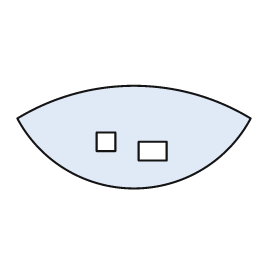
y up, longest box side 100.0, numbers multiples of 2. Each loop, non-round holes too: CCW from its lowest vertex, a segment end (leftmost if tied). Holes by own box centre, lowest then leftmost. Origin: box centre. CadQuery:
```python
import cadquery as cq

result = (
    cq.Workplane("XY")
    .moveTo(-50.0, 8.0)
    .threePointArc((0.0, -22.0), (50.0, 8.0))
    .threePointArc((0.0, 22.0), (-50.0, 8.0))
    .close()
    .moveTo(2.0, -10.0)
    .lineTo(14.0, -10.0)
    .lineTo(14.0, -2.0)
    .lineTo(2.0, -2.0)
    .close()
    .moveTo(-16.0, -6.0)
    .lineTo(-8.0, -6.0)
    .lineTo(-8.0, 2.0)
    .lineTo(-16.0, 2.0)
    .close()
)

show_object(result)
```